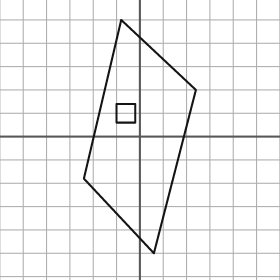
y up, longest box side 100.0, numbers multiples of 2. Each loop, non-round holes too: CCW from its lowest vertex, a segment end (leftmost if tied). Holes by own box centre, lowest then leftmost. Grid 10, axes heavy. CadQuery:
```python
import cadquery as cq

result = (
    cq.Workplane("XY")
    .moveTo(6.0, -50.0)
    .lineTo(24.0, 20.0)
    .lineTo(-8.0, 50.0)
    .lineTo(-24.0, -18.0)
    .close()
    .moveTo(-10.0, 6.0)
    .lineTo(-2.0, 6.0)
    .lineTo(-2.0, 14.0)
    .lineTo(-10.0, 14.0)
    .close()
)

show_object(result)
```